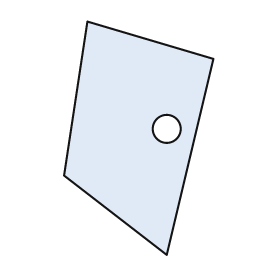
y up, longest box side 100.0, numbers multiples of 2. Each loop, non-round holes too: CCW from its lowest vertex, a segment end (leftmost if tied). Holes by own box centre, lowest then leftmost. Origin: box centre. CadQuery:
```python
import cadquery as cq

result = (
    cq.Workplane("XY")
    .moveTo(12.0, -50.0)
    .lineTo(32.0, 34.0)
    .lineTo(-22.0, 50.0)
    .lineTo(-32.0, -16.0)
    .close()
    .moveTo(12.0, 4.0)
    .circle(6.0)
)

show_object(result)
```